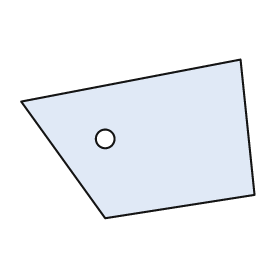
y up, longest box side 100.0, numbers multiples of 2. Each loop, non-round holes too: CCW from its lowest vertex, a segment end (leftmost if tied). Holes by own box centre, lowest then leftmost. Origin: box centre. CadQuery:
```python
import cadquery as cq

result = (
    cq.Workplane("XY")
    .moveTo(-14.0, -34.0)
    .lineTo(50.0, -24.0)
    .lineTo(44.0, 34.0)
    .lineTo(-50.0, 16.0)
    .close()
    .moveTo(-14.0, 0.0)
    .circle(4.0)
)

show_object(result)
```